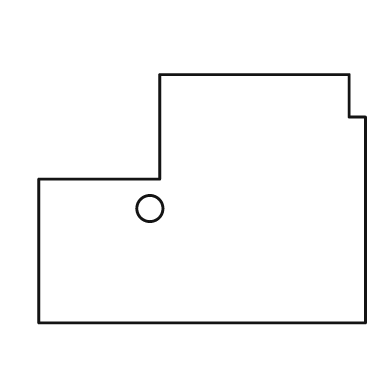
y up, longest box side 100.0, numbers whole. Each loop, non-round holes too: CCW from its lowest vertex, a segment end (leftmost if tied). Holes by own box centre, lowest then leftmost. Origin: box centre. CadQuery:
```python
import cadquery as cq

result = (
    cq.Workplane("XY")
    .moveTo(-50.0, -38.0)
    .lineTo(50.0, -38.0)
    .lineTo(50.0, 25.0)
    .lineTo(45.0, 25.0)
    .lineTo(45.0, 38.0)
    .lineTo(-13.0, 38.0)
    .lineTo(-13.0, 6.0)
    .lineTo(-50.0, 6.0)
    .close()
    .moveTo(-16.0, -3.0)
    .circle(4.0)
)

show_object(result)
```